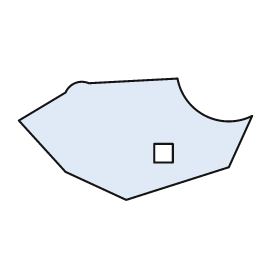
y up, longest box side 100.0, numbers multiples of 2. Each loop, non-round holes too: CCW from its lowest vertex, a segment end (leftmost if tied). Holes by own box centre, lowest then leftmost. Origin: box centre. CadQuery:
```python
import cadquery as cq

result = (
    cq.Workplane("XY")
    .moveTo(-4.0, -26.0)
    .lineTo(40.0, -12.0)
    .lineTo(50.0, 10.0)
    .threePointArc((30.0, 10.0), (18.0, 26.0))
    .lineTo(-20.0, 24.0)
    .threePointArc((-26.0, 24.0), (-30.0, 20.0))
    .lineTo(-50.0, 8.0)
    .lineTo(-30.0, -14.0)
    .close()
    .moveTo(8.0, -10.0)
    .lineTo(16.0, -10.0)
    .lineTo(16.0, -2.0)
    .lineTo(8.0, -2.0)
    .close()
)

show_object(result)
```